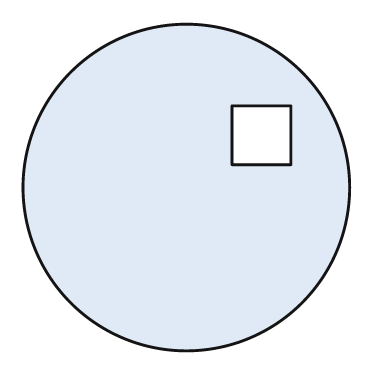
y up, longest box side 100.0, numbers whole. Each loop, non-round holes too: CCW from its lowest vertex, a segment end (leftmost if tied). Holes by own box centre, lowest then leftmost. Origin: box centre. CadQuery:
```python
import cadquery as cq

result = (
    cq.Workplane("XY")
    .moveTo(0.0, 0.0)
    .circle(50.0)
    .moveTo(14.0, 7.0)
    .lineTo(32.0, 7.0)
    .lineTo(32.0, 25.0)
    .lineTo(14.0, 25.0)
    .close()
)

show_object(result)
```